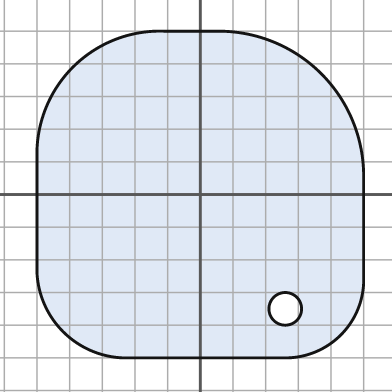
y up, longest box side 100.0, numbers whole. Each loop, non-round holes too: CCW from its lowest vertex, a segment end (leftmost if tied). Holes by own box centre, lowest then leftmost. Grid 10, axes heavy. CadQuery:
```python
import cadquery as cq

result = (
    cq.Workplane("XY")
    .moveTo(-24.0, -50.0)
    .lineTo(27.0, -50.0)
    .threePointArc((43.0, -43.0), (50.0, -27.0))
    .lineTo(50.0, 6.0)
    .threePointArc((37.0, 37.0), (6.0, 50.0))
    .lineTo(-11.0, 50.0)
    .threePointArc((-39.0, 39.0), (-50.0, 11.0))
    .lineTo(-50.0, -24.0)
    .threePointArc((-42.0, -42.0), (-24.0, -50.0))
    .close()
    .moveTo(26.0, -35.0)
    .circle(5.0)
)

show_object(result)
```